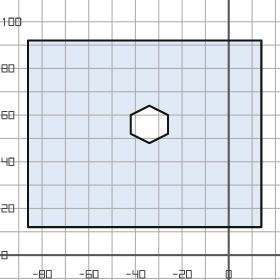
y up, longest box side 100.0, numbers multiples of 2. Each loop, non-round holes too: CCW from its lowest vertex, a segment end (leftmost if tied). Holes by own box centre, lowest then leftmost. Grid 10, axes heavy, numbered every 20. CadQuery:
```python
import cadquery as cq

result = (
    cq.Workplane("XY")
    .moveTo(-86.0, 12.0)
    .lineTo(14.0, 12.0)
    .lineTo(14.0, 92.0)
    .lineTo(-86.0, 92.0)
    .close()
    .moveTo(-34.0, 48.0)
    .lineTo(-26.0, 52.0)
    .lineTo(-26.0, 60.0)
    .lineTo(-34.0, 64.0)
    .lineTo(-42.0, 60.0)
    .lineTo(-42.0, 52.0)
    .close()
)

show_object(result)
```